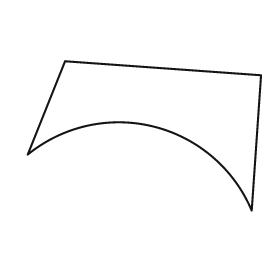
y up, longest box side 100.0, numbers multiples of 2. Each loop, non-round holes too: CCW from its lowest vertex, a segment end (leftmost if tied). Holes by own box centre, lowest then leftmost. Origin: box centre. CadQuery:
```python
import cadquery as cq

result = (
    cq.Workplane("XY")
    .moveTo(46.0, -32.0)
    .lineTo(50.0, 26.0)
    .lineTo(-34.0, 32.0)
    .lineTo(-50.0, -8.0)
    .threePointArc((4.0, 4.0), (46.0, -32.0))
    .close()
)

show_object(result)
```